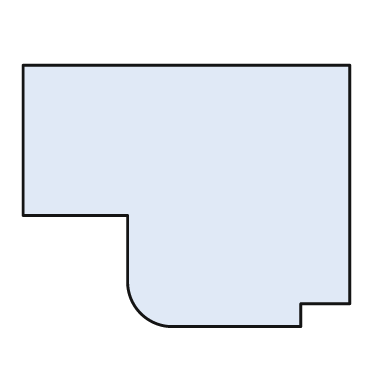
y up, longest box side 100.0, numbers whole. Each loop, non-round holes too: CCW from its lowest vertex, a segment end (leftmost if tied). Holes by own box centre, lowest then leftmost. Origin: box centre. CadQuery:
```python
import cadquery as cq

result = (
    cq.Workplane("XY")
    .moveTo(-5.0, -40.0)
    .lineTo(35.0, -40.0)
    .lineTo(35.0, -33.0)
    .lineTo(50.0, -33.0)
    .lineTo(50.0, 40.0)
    .lineTo(-50.0, 40.0)
    .lineTo(-50.0, -6.0)
    .lineTo(-18.0, -6.0)
    .lineTo(-18.0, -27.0)
    .threePointArc((-14.0, -36.0), (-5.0, -40.0))
    .close()
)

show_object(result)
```